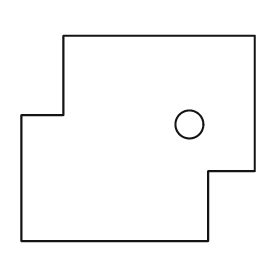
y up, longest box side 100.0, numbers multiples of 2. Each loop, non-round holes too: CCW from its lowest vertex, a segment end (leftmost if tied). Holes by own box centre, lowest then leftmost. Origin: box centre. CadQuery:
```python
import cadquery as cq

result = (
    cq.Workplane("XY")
    .moveTo(-50.0, -44.0)
    .lineTo(30.0, -44.0)
    .lineTo(30.0, -14.0)
    .lineTo(50.0, -14.0)
    .lineTo(50.0, 44.0)
    .lineTo(-32.0, 44.0)
    .lineTo(-32.0, 10.0)
    .lineTo(-50.0, 10.0)
    .close()
    .moveTo(22.0, 6.0)
    .circle(6.0)
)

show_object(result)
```